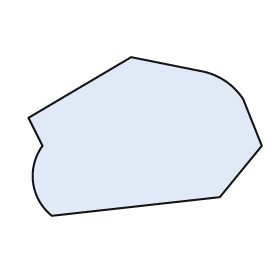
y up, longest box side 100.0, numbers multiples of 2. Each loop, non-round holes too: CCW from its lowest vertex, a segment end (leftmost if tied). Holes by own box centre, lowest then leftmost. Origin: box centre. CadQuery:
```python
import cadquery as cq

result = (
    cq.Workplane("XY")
    .moveTo(-40.0, -34.0)
    .lineTo(32.0, -26.0)
    .lineTo(50.0, -4.0)
    .lineTo(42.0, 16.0)
    .threePointArc((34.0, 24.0), (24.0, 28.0))
    .lineTo(-6.0, 34.0)
    .lineTo(-50.0, 8.0)
    .lineTo(-44.0, -4.0)
    .threePointArc((-48.0, -20.0), (-40.0, -34.0))
    .close()
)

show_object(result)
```